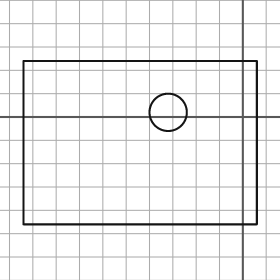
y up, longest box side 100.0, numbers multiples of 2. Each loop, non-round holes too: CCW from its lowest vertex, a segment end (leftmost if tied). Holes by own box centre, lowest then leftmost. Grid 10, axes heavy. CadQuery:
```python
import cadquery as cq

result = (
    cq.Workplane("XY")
    .moveTo(-94.0, -46.0)
    .lineTo(6.0, -46.0)
    .lineTo(6.0, 24.0)
    .lineTo(-94.0, 24.0)
    .close()
    .moveTo(-32.0, 2.0)
    .circle(8.0)
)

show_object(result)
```